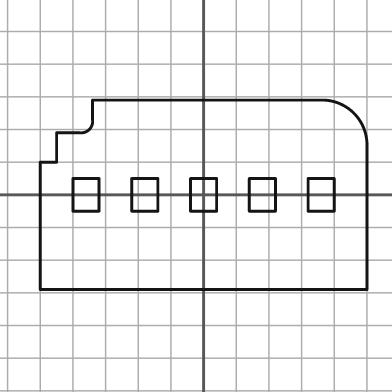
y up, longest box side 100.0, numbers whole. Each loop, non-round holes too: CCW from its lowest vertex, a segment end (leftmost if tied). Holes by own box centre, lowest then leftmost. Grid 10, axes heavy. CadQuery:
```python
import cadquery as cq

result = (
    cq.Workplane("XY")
    .moveTo(-50.0, -29.0)
    .lineTo(50.0, -29.0)
    .lineTo(50.0, 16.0)
    .threePointArc((46.0, 25.0), (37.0, 29.0))
    .lineTo(-34.0, 29.0)
    .lineTo(-34.0, 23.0)
    .threePointArc((-35.0, 20.0), (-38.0, 19.0))
    .lineTo(-45.0, 19.0)
    .lineTo(-45.0, 10.0)
    .lineTo(-50.0, 10.0)
    .close()
    .moveTo(-40.0, -5.0)
    .lineTo(-32.0, -5.0)
    .lineTo(-32.0, 5.0)
    .lineTo(-40.0, 5.0)
    .close()
    .moveTo(-22.0, -5.0)
    .lineTo(-14.0, -5.0)
    .lineTo(-14.0, 5.0)
    .lineTo(-22.0, 5.0)
    .close()
    .moveTo(-4.0, -5.0)
    .lineTo(4.0, -5.0)
    .lineTo(4.0, 5.0)
    .lineTo(-4.0, 5.0)
    .close()
    .moveTo(14.0, -5.0)
    .lineTo(22.0, -5.0)
    .lineTo(22.0, 5.0)
    .lineTo(14.0, 5.0)
    .close()
    .moveTo(32.0, -5.0)
    .lineTo(40.0, -5.0)
    .lineTo(40.0, 5.0)
    .lineTo(32.0, 5.0)
    .close()
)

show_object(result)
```